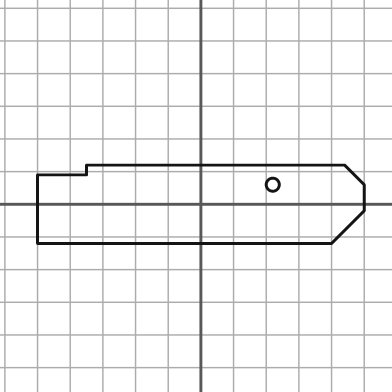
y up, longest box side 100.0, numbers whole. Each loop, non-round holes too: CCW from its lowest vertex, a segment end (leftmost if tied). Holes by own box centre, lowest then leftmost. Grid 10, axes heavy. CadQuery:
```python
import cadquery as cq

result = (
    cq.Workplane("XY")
    .moveTo(-50.0, -12.0)
    .lineTo(40.0, -12.0)
    .lineTo(50.0, -2.0)
    .lineTo(50.0, 6.0)
    .lineTo(44.0, 12.0)
    .lineTo(-35.0, 12.0)
    .lineTo(-35.0, 9.0)
    .lineTo(-50.0, 9.0)
    .close()
    .moveTo(22.0, 6.0)
    .circle(2.0)
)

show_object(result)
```